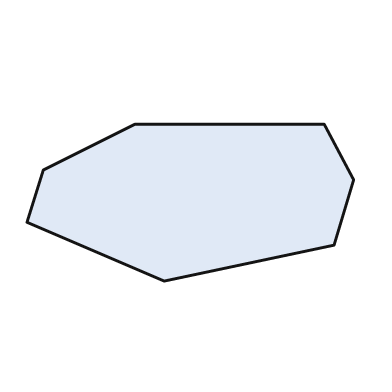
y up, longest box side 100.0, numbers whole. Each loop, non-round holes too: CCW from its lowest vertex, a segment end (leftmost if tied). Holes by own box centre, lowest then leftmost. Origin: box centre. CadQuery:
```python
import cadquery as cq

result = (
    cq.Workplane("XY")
    .moveTo(-8.0, -24.0)
    .lineTo(44.0, -13.0)
    .lineTo(50.0, 7.0)
    .lineTo(41.0, 24.0)
    .lineTo(-17.0, 24.0)
    .lineTo(-45.0, 10.0)
    .lineTo(-50.0, -6.0)
    .close()
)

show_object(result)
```